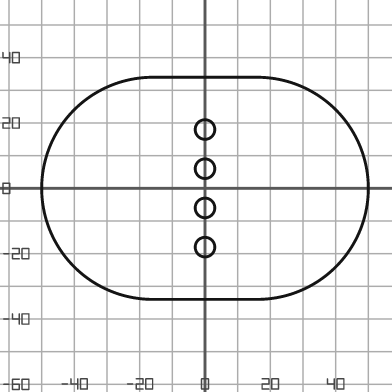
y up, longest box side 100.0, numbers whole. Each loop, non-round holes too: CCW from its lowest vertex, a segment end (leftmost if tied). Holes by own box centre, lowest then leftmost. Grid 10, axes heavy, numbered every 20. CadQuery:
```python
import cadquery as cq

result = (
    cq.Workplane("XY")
    .moveTo(-16.0, -34.0)
    .lineTo(16.0, -34.0)
    .threePointArc((50.0, 0.0), (16.0, 34.0))
    .lineTo(-16.0, 34.0)
    .threePointArc((-50.0, 0.0), (-16.0, -34.0))
    .close()
    .moveTo(0.0, -18.0)
    .circle(3.0)
    .moveTo(0.0, -6.0)
    .circle(3.0)
    .moveTo(0.0, 6.0)
    .circle(3.0)
    .moveTo(0.0, 18.0)
    .circle(3.0)
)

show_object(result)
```